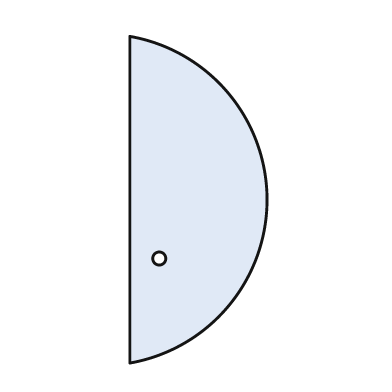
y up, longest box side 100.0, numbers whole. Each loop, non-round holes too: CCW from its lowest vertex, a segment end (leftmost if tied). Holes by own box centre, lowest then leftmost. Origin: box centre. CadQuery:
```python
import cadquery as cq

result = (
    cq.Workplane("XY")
    .moveTo(-21.0, -50.0)
    .threePointArc((21.0, 0.0), (-21.0, 50.0))
    .close()
    .moveTo(-12.0, -18.0)
    .circle(2.0)
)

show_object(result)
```